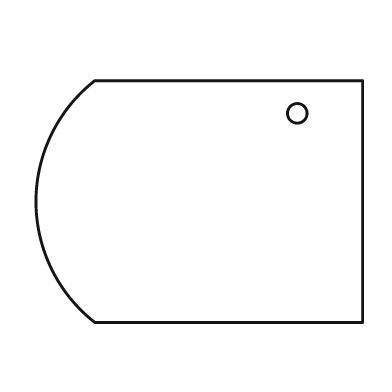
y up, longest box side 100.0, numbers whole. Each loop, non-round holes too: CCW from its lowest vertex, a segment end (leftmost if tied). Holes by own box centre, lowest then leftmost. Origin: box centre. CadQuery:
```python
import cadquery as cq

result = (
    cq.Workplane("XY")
    .moveTo(-32.0, -37.0)
    .lineTo(50.0, -37.0)
    .lineTo(50.0, 37.0)
    .lineTo(-32.0, 37.0)
    .threePointArc((-50.0, 0.0), (-32.0, -37.0))
    .close()
    .moveTo(30.0, 27.0)
    .circle(3.0)
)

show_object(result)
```